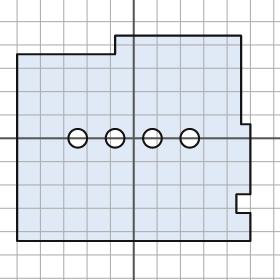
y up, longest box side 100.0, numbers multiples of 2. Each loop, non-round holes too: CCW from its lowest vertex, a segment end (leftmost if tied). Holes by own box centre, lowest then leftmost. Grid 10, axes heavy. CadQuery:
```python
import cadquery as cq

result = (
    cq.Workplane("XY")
    .moveTo(-50.0, -44.0)
    .lineTo(50.0, -44.0)
    .lineTo(50.0, -32.0)
    .lineTo(44.0, -32.0)
    .lineTo(44.0, -24.0)
    .lineTo(50.0, -24.0)
    .lineTo(50.0, 6.0)
    .lineTo(46.0, 6.0)
    .lineTo(46.0, 44.0)
    .lineTo(-8.0, 44.0)
    .lineTo(-8.0, 36.0)
    .lineTo(-50.0, 36.0)
    .close()
    .moveTo(-24.0, 0.0)
    .circle(4.0)
    .moveTo(-8.0, 0.0)
    .circle(4.0)
    .moveTo(8.0, 0.0)
    .circle(4.0)
    .moveTo(24.0, 0.0)
    .circle(4.0)
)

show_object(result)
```